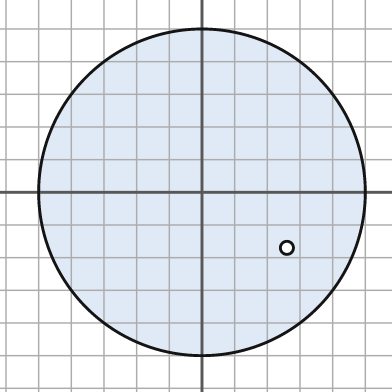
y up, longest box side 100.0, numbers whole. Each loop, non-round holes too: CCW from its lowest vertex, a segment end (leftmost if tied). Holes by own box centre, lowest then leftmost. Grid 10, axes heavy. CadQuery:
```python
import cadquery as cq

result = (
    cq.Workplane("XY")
    .moveTo(0.0, 0.0)
    .circle(50.0)
    .moveTo(26.0, -17.0)
    .circle(2.0)
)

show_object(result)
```